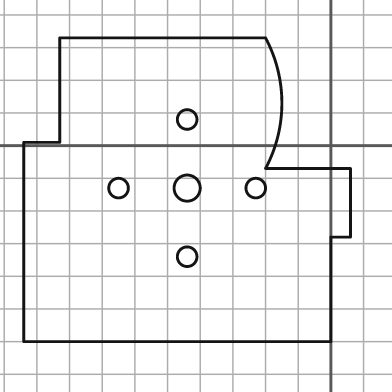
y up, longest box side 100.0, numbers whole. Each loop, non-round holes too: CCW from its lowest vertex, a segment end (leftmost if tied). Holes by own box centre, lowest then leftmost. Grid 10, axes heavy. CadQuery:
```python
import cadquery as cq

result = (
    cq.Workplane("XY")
    .moveTo(-94.0, -60.0)
    .lineTo(0.0, -60.0)
    .lineTo(0.0, -28.0)
    .lineTo(6.0, -28.0)
    .lineTo(6.0, -7.0)
    .lineTo(-20.0, -7.0)
    .threePointArc((-15.0, 13.0), (-20.0, 33.0))
    .lineTo(-83.0, 33.0)
    .lineTo(-83.0, 1.0)
    .lineTo(-94.0, 1.0)
    .close()
    .moveTo(-44.0, -34.0)
    .circle(3.0)
    .moveTo(-65.0, -13.0)
    .circle(3.0)
    .moveTo(-44.0, -13.0)
    .circle(4.0)
    .moveTo(-23.0, -13.0)
    .circle(3.0)
    .moveTo(-44.0, 8.0)
    .circle(3.0)
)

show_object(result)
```